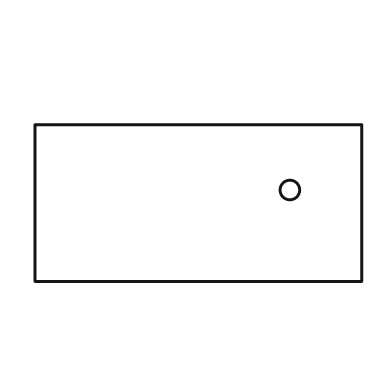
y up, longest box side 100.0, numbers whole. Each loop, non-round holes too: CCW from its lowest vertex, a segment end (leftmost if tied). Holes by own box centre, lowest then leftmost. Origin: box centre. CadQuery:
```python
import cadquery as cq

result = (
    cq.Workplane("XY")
    .moveTo(-50.0, -24.0)
    .lineTo(50.0, -24.0)
    .lineTo(50.0, 24.0)
    .lineTo(-50.0, 24.0)
    .close()
    .moveTo(28.0, 4.0)
    .circle(3.0)
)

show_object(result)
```